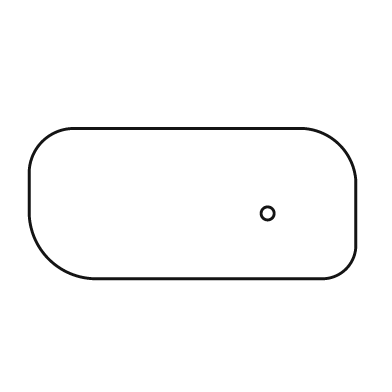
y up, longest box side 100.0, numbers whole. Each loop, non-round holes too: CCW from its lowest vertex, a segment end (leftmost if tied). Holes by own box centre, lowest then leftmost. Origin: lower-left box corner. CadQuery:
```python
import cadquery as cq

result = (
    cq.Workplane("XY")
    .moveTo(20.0, 0.0)
    .lineTo(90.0, 0.0)
    .threePointArc((97.0, 3.0), (100.0, 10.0))
    .lineTo(100.0, 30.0)
    .threePointArc((95.0, 41.0), (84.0, 46.0))
    .lineTo(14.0, 46.0)
    .threePointArc((4.0, 42.0), (0.0, 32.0))
    .lineTo(0.0, 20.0)
    .threePointArc((6.0, 6.0), (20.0, 0.0))
    .close()
    .moveTo(73.0, 20.0)
    .circle(2.0)
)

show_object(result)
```